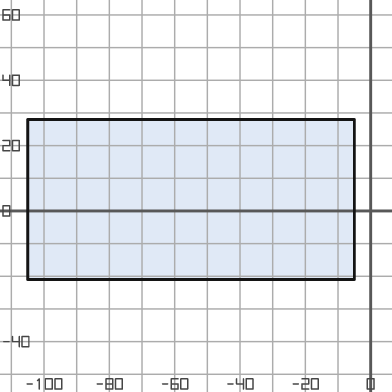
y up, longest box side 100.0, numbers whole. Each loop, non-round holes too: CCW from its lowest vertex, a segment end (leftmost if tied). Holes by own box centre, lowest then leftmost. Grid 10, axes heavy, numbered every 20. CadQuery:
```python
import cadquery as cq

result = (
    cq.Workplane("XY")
    .moveTo(-105.0, -21.0)
    .lineTo(-5.0, -21.0)
    .lineTo(-5.0, 28.0)
    .lineTo(-105.0, 28.0)
    .close()
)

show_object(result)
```